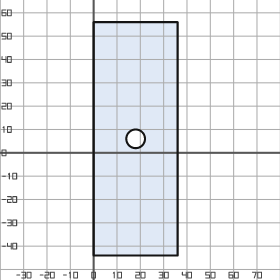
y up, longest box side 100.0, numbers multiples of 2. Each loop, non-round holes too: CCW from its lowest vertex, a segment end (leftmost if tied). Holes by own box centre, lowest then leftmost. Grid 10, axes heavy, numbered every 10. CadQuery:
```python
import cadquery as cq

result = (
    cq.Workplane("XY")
    .moveTo(0.0, -44.0)
    .lineTo(36.0, -44.0)
    .lineTo(36.0, 56.0)
    .lineTo(0.0, 56.0)
    .close()
    .moveTo(18.0, 6.0)
    .circle(4.0)
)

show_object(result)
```